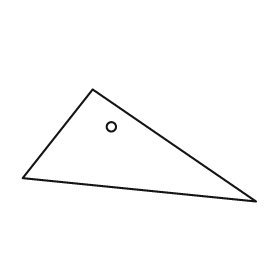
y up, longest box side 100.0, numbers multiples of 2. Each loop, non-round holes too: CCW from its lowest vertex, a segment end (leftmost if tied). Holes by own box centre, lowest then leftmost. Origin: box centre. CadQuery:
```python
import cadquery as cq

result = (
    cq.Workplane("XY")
    .moveTo(50.0, -24.0)
    .lineTo(-20.0, 24.0)
    .lineTo(-50.0, -14.0)
    .close()
    .moveTo(-12.0, 8.0)
    .circle(2.0)
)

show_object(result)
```